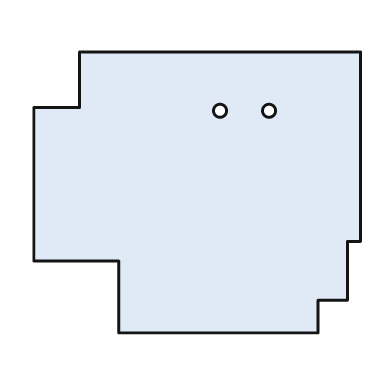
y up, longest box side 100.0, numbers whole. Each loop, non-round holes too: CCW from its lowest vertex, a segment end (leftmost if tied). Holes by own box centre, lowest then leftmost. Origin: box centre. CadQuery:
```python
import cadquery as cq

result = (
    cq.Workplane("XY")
    .moveTo(-24.0, -43.0)
    .lineTo(37.0, -43.0)
    .lineTo(37.0, -33.0)
    .lineTo(46.0, -33.0)
    .lineTo(46.0, -15.0)
    .lineTo(50.0, -15.0)
    .lineTo(50.0, 43.0)
    .lineTo(-36.0, 43.0)
    .lineTo(-36.0, 26.0)
    .lineTo(-50.0, 26.0)
    .lineTo(-50.0, -21.0)
    .lineTo(-24.0, -21.0)
    .close()
    .moveTo(7.0, 25.0)
    .circle(2.0)
    .moveTo(22.0, 25.0)
    .circle(2.0)
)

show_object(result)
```